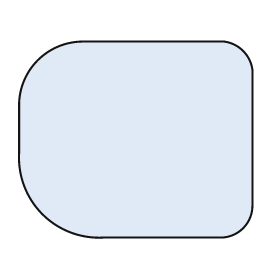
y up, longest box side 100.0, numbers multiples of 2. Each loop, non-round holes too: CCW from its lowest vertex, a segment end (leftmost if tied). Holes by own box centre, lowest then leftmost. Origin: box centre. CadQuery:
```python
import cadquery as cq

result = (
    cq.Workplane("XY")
    .moveTo(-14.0, -42.0)
    .lineTo(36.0, -42.0)
    .threePointArc((46.0, -38.0), (50.0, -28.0))
    .lineTo(50.0, 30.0)
    .threePointArc((46.0, 38.0), (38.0, 42.0))
    .lineTo(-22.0, 42.0)
    .threePointArc((-42.0, 34.0), (-50.0, 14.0))
    .lineTo(-50.0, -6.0)
    .threePointArc((-40.0, -32.0), (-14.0, -42.0))
    .close()
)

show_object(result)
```